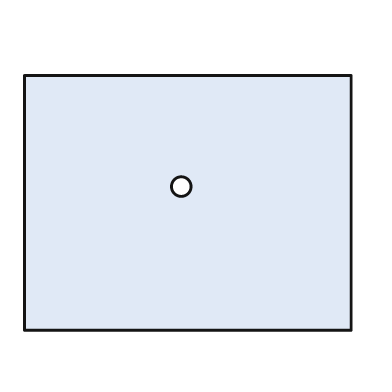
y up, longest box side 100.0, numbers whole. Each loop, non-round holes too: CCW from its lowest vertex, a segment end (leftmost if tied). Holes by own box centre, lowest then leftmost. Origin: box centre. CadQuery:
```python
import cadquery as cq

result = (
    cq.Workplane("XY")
    .moveTo(-50.0, -39.0)
    .lineTo(50.0, -39.0)
    .lineTo(50.0, 39.0)
    .lineTo(-50.0, 39.0)
    .close()
    .moveTo(-2.0, 5.0)
    .circle(3.0)
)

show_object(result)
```